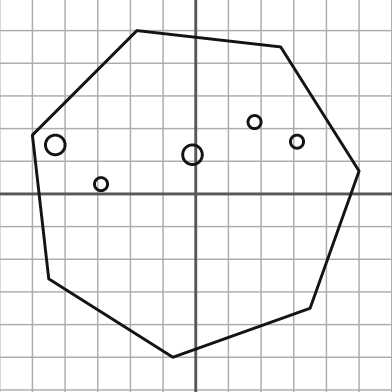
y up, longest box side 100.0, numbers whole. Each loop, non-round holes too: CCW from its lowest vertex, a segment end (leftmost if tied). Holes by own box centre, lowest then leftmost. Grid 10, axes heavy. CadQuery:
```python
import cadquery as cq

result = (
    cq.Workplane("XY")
    .moveTo(-7.0, -50.0)
    .lineTo(35.0, -35.0)
    .lineTo(50.0, 7.0)
    .lineTo(26.0, 45.0)
    .lineTo(-18.0, 50.0)
    .lineTo(-50.0, 18.0)
    .lineTo(-45.0, -26.0)
    .close()
    .moveTo(-29.0, 3.0)
    .circle(2.0)
    .moveTo(-1.0, 12.0)
    .circle(3.0)
    .moveTo(-43.0, 15.0)
    .circle(3.0)
    .moveTo(31.0, 16.0)
    .circle(2.0)
    .moveTo(18.0, 22.0)
    .circle(2.0)
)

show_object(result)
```